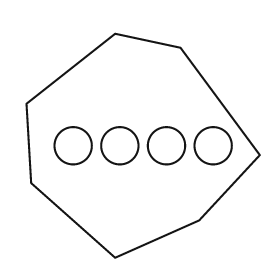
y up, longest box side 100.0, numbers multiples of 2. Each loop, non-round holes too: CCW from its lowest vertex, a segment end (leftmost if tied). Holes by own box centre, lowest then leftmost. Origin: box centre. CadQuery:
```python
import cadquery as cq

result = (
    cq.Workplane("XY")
    .moveTo(-12.0, -48.0)
    .lineTo(24.0, -32.0)
    .lineTo(50.0, -4.0)
    .lineTo(16.0, 42.0)
    .lineTo(-12.0, 48.0)
    .lineTo(-50.0, 18.0)
    .lineTo(-48.0, -16.0)
    .close()
    .moveTo(-30.0, 0.0)
    .circle(8.0)
    .moveTo(-10.0, 0.0)
    .circle(8.0)
    .moveTo(10.0, 0.0)
    .circle(8.0)
    .moveTo(30.0, 0.0)
    .circle(8.0)
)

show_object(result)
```